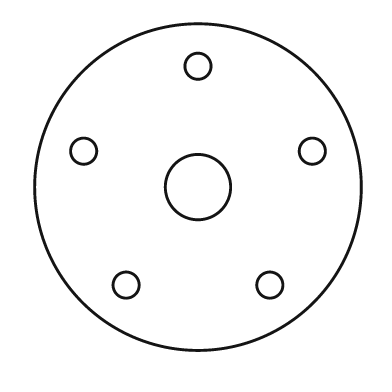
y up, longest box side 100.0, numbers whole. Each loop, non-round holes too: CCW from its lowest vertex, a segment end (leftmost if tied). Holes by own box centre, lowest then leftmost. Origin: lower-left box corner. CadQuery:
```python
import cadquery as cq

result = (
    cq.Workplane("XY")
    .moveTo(50.0, 50.0)
    .circle(50.0)
    .moveTo(28.0, 20.0)
    .circle(4.0)
    .moveTo(72.0, 20.0)
    .circle(4.0)
    .moveTo(50.0, 50.0)
    .circle(10.0)
    .moveTo(15.0, 61.0)
    .circle(4.0)
    .moveTo(85.0, 61.0)
    .circle(4.0)
    .moveTo(50.0, 87.0)
    .circle(4.0)
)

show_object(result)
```